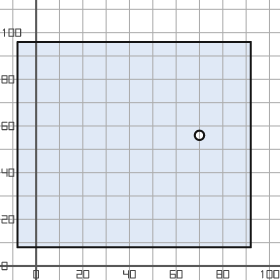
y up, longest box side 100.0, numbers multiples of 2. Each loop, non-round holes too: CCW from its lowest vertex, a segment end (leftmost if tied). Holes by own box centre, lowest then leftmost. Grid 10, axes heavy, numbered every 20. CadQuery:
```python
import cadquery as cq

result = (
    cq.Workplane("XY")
    .moveTo(-8.0, 8.0)
    .lineTo(92.0, 8.0)
    .lineTo(92.0, 96.0)
    .lineTo(-8.0, 96.0)
    .close()
    .moveTo(70.0, 56.0)
    .circle(2.0)
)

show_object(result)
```